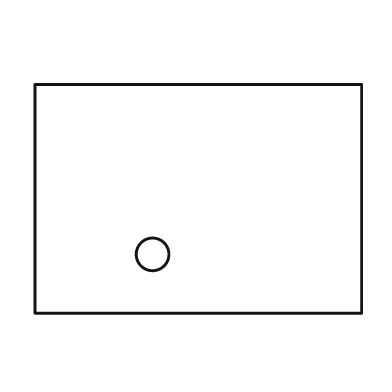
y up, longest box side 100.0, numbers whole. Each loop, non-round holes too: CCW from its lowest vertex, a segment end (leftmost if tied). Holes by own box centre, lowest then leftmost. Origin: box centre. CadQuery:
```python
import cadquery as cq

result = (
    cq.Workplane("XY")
    .moveTo(-50.0, -35.0)
    .lineTo(50.0, -35.0)
    .lineTo(50.0, 35.0)
    .lineTo(-50.0, 35.0)
    .close()
    .moveTo(-14.0, -17.0)
    .circle(5.0)
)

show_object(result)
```